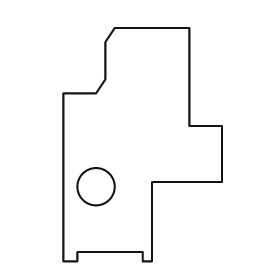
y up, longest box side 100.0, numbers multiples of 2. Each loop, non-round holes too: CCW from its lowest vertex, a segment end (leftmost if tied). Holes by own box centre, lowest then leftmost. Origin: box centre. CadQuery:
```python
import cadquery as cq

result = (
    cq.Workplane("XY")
    .moveTo(-34.0, -50.0)
    .lineTo(-28.0, -50.0)
    .lineTo(-28.0, -46.0)
    .lineTo(0.0, -46.0)
    .lineTo(0.0, -50.0)
    .lineTo(4.0, -50.0)
    .lineTo(4.0, -16.0)
    .lineTo(34.0, -16.0)
    .lineTo(34.0, 8.0)
    .lineTo(20.0, 8.0)
    .lineTo(20.0, 50.0)
    .lineTo(-12.0, 50.0)
    .lineTo(-16.0, 44.0)
    .lineTo(-16.0, 28.0)
    .lineTo(-20.0, 22.0)
    .lineTo(-34.0, 22.0)
    .close()
    .moveTo(-20.0, -18.0)
    .circle(8.0)
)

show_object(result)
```